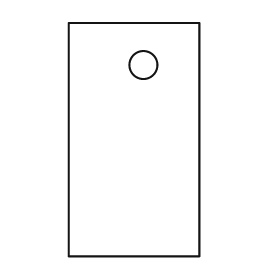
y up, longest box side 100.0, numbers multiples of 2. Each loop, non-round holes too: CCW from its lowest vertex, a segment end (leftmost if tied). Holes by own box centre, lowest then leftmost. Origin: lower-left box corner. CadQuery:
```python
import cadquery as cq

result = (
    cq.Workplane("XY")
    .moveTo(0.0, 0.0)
    .lineTo(56.0, 0.0)
    .lineTo(56.0, 100.0)
    .lineTo(0.0, 100.0)
    .close()
    .moveTo(32.0, 82.0)
    .circle(6.0)
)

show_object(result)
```